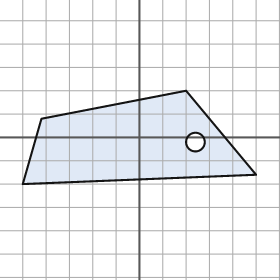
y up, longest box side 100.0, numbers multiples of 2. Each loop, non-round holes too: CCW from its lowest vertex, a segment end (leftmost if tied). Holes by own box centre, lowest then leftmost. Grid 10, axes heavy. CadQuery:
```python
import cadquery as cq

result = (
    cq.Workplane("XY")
    .moveTo(-50.0, -20.0)
    .lineTo(50.0, -16.0)
    .lineTo(20.0, 20.0)
    .lineTo(-42.0, 8.0)
    .close()
    .moveTo(24.0, -2.0)
    .circle(4.0)
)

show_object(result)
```